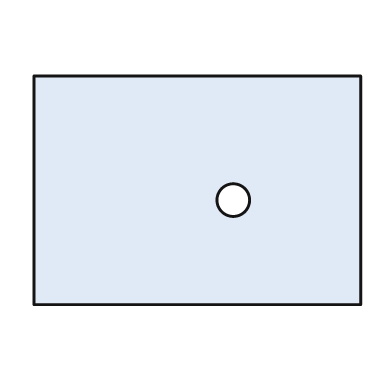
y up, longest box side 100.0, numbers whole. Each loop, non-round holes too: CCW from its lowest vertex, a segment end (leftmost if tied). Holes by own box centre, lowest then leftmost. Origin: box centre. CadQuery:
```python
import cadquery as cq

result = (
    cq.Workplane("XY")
    .moveTo(-50.0, -35.0)
    .lineTo(50.0, -35.0)
    .lineTo(50.0, 35.0)
    .lineTo(-50.0, 35.0)
    .close()
    .moveTo(11.0, -3.0)
    .circle(5.0)
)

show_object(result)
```